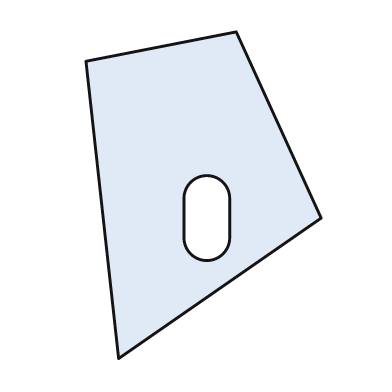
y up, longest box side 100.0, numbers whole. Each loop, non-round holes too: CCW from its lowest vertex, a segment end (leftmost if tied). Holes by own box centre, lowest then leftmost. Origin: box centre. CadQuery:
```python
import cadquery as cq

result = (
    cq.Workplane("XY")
    .moveTo(-26.0, -50.0)
    .lineTo(36.0, -7.0)
    .lineTo(10.0, 50.0)
    .lineTo(-36.0, 41.0)
    .close()
    .moveTo(-6.0, -13.0)
    .threePointArc((1.0, -20.0), (8.0, -13.0))
    .lineTo(8.0, -1.0)
    .threePointArc((1.0, 6.0), (-6.0, -1.0))
    .close()
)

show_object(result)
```